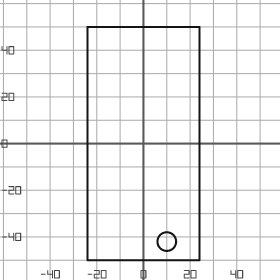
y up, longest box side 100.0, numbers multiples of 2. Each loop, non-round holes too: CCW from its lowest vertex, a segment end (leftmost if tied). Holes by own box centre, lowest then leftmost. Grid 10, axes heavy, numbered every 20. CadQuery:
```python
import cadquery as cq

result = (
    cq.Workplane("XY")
    .moveTo(-24.0, -50.0)
    .lineTo(24.0, -50.0)
    .lineTo(24.0, 50.0)
    .lineTo(-24.0, 50.0)
    .close()
    .moveTo(10.0, -42.0)
    .circle(4.0)
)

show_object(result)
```